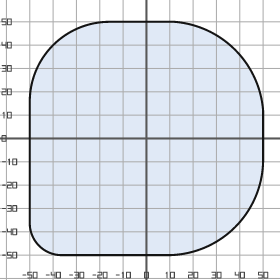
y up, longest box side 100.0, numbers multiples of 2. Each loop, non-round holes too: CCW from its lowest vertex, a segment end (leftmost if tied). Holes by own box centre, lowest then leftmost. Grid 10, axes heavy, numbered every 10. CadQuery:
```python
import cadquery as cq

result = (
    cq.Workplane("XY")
    .moveTo(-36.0, -50.0)
    .lineTo(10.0, -50.0)
    .threePointArc((38.0, -38.0), (50.0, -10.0))
    .lineTo(50.0, 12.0)
    .threePointArc((38.0, 38.0), (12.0, 50.0))
    .lineTo(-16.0, 50.0)
    .threePointArc((-40.0, 40.0), (-50.0, 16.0))
    .lineTo(-50.0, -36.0)
    .threePointArc((-46.0, -46.0), (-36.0, -50.0))
    .close()
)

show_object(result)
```